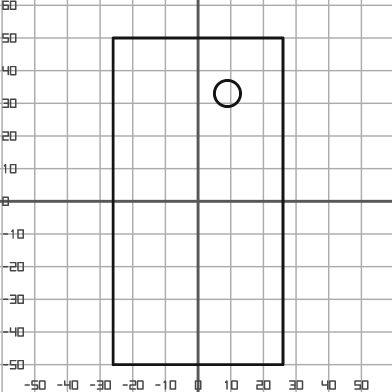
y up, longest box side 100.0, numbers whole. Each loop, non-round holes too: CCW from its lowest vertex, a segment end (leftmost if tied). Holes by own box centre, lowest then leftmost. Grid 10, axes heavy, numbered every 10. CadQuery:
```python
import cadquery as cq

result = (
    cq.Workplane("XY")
    .moveTo(-26.0, -50.0)
    .lineTo(26.0, -50.0)
    .lineTo(26.0, 50.0)
    .lineTo(-26.0, 50.0)
    .close()
    .moveTo(9.0, 33.0)
    .circle(4.0)
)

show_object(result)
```